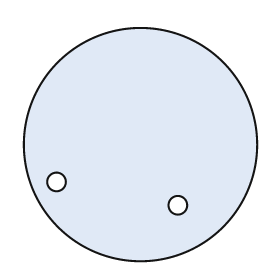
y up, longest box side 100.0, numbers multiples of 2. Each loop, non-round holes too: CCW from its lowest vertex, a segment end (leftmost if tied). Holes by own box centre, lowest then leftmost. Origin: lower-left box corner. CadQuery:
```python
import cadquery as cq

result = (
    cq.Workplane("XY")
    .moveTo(50.0, 50.0)
    .circle(50.0)
    .moveTo(66.0, 24.0)
    .circle(4.0)
    .moveTo(14.0, 34.0)
    .circle(4.0)
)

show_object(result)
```